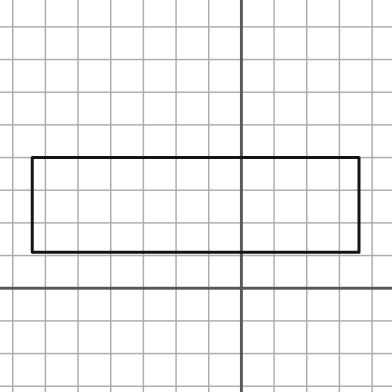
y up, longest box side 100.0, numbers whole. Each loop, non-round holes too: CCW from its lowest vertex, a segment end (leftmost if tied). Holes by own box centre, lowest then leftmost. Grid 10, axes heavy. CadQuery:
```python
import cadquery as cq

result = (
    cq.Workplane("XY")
    .moveTo(-64.0, 11.0)
    .lineTo(36.0, 11.0)
    .lineTo(36.0, 40.0)
    .lineTo(-64.0, 40.0)
    .close()
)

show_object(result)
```